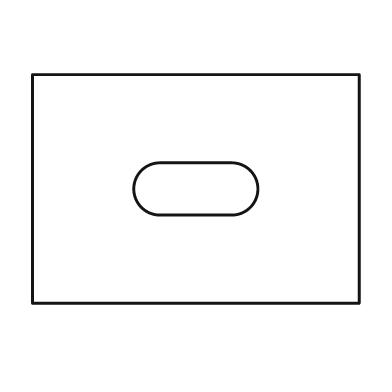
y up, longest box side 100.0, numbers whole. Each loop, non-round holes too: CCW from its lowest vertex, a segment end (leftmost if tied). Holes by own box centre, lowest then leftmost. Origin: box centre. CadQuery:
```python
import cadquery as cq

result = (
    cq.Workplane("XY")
    .moveTo(-50.0, -35.0)
    .lineTo(50.0, -35.0)
    .lineTo(50.0, 35.0)
    .lineTo(-50.0, 35.0)
    .close()
    .moveTo(-11.0, -8.0)
    .lineTo(11.0, -8.0)
    .threePointArc((19.0, 0.0), (11.0, 8.0))
    .lineTo(-11.0, 8.0)
    .threePointArc((-19.0, 0.0), (-11.0, -8.0))
    .close()
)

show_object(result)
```